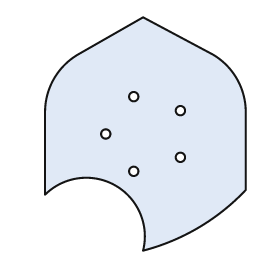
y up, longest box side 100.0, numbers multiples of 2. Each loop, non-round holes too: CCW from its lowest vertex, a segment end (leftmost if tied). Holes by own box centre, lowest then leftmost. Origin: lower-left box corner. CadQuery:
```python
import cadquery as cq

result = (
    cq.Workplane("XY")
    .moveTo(42.0, 0.0)
    .threePointArc((66.0, 10.0), (86.0, 26.0))
    .lineTo(86.0, 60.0)
    .threePointArc((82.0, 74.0), (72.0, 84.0))
    .lineTo(42.0, 100.0)
    .lineTo(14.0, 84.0)
    .threePointArc((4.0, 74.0), (0.0, 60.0))
    .lineTo(0.0, 24.0)
    .threePointArc((30.0, 28.0), (42.0, 0.0))
    .close()
    .moveTo(38.0, 34.0)
    .circle(2.0)
    .moveTo(58.0, 40.0)
    .circle(2.0)
    .moveTo(26.0, 50.0)
    .circle(2.0)
    .moveTo(58.0, 60.0)
    .circle(2.0)
    .moveTo(38.0, 66.0)
    .circle(2.0)
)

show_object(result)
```